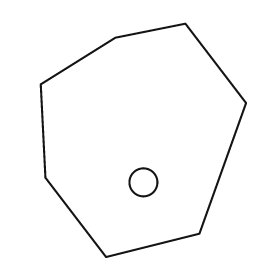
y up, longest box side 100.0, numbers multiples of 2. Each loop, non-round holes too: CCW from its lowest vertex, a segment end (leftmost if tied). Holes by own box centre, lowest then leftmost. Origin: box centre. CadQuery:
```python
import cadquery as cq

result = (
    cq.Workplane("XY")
    .moveTo(-16.0, -50.0)
    .lineTo(24.0, -40.0)
    .lineTo(44.0, 16.0)
    .lineTo(18.0, 50.0)
    .lineTo(-12.0, 44.0)
    .lineTo(-44.0, 24.0)
    .lineTo(-42.0, -16.0)
    .close()
    .moveTo(0.0, -18.0)
    .circle(6.0)
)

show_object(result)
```